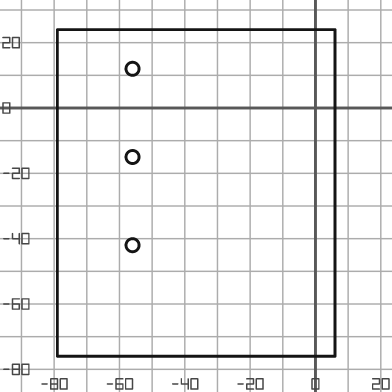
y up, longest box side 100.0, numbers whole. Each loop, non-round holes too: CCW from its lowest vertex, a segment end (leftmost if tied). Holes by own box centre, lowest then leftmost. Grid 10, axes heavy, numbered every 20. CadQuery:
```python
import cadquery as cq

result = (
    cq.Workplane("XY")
    .moveTo(-79.0, -76.0)
    .lineTo(6.0, -76.0)
    .lineTo(6.0, 24.0)
    .lineTo(-79.0, 24.0)
    .close()
    .moveTo(-56.0, -42.0)
    .circle(2.0)
    .moveTo(-56.0, -15.0)
    .circle(2.0)
    .moveTo(-56.0, 12.0)
    .circle(2.0)
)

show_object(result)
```